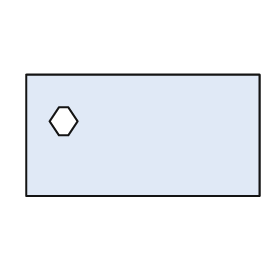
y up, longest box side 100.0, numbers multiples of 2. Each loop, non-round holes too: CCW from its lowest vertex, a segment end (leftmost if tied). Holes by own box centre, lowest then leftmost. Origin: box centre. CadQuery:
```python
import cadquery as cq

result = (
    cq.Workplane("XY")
    .moveTo(-50.0, -26.0)
    .lineTo(50.0, -26.0)
    .lineTo(50.0, 26.0)
    .lineTo(-50.0, 26.0)
    .close()
    .moveTo(-36.0, 0.0)
    .lineTo(-32.0, 0.0)
    .lineTo(-28.0, 6.0)
    .lineTo(-32.0, 12.0)
    .lineTo(-36.0, 12.0)
    .lineTo(-40.0, 6.0)
    .close()
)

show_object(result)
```